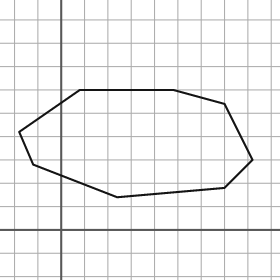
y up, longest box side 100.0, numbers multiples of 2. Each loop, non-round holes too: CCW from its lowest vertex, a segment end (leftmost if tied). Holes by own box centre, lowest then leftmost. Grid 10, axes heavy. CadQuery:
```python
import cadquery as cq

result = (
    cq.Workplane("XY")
    .moveTo(24.0, 14.0)
    .lineTo(70.0, 18.0)
    .lineTo(82.0, 30.0)
    .lineTo(70.0, 54.0)
    .lineTo(48.0, 60.0)
    .lineTo(8.0, 60.0)
    .lineTo(-18.0, 42.0)
    .lineTo(-12.0, 28.0)
    .close()
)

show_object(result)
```